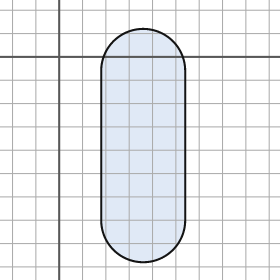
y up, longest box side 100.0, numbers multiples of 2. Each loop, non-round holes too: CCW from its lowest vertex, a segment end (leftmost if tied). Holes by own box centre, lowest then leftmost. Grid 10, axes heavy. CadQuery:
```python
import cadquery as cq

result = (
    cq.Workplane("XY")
    .moveTo(18.0, -70.0)
    .threePointArc((36.0, -88.0), (54.0, -70.0))
    .lineTo(54.0, -6.0)
    .threePointArc((36.0, 12.0), (18.0, -6.0))
    .close()
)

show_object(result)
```